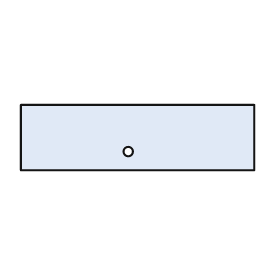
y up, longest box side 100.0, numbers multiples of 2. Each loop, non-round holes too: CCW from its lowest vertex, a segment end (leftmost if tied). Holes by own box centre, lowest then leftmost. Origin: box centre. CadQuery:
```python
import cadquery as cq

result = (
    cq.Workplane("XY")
    .moveTo(-50.0, -14.0)
    .lineTo(50.0, -14.0)
    .lineTo(50.0, 14.0)
    .lineTo(-50.0, 14.0)
    .close()
    .moveTo(-4.0, -6.0)
    .circle(2.0)
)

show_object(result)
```